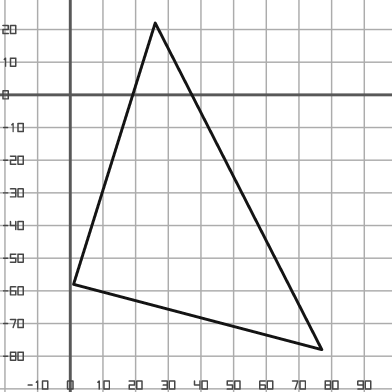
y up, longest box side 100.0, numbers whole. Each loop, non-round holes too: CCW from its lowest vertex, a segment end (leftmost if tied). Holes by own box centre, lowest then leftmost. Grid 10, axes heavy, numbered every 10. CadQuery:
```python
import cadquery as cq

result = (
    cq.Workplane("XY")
    .moveTo(77.0, -78.0)
    .lineTo(26.0, 22.0)
    .lineTo(1.0, -58.0)
    .close()
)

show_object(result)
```